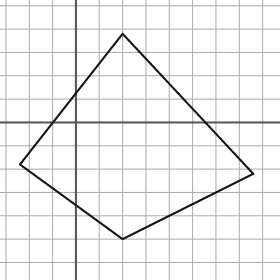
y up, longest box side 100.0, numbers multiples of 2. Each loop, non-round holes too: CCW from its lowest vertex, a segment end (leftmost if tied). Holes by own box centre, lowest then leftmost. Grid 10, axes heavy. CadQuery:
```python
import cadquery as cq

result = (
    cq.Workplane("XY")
    .moveTo(20.0, -50.0)
    .lineTo(76.0, -22.0)
    .lineTo(20.0, 38.0)
    .lineTo(-24.0, -18.0)
    .close()
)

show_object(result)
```